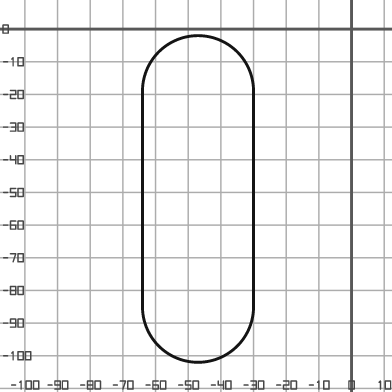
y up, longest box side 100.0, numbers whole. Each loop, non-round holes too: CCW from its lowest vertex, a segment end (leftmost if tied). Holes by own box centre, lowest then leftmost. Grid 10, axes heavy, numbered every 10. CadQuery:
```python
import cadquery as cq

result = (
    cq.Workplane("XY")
    .moveTo(-64.0, -85.0)
    .threePointArc((-47.0, -102.0), (-30.0, -85.0))
    .lineTo(-30.0, -19.0)
    .threePointArc((-47.0, -2.0), (-64.0, -19.0))
    .close()
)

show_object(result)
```